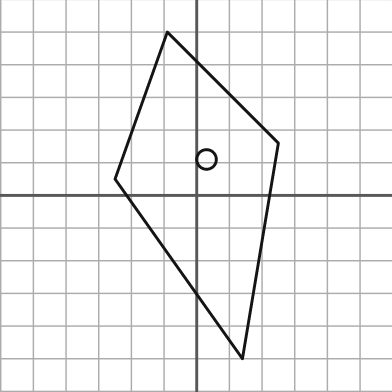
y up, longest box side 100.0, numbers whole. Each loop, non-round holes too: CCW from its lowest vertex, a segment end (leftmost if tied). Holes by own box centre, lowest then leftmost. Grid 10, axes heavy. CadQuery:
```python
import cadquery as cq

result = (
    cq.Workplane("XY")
    .moveTo(14.0, -50.0)
    .lineTo(25.0, 16.0)
    .lineTo(-9.0, 50.0)
    .lineTo(-25.0, 5.0)
    .close()
    .moveTo(3.0, 11.0)
    .circle(3.0)
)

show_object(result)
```